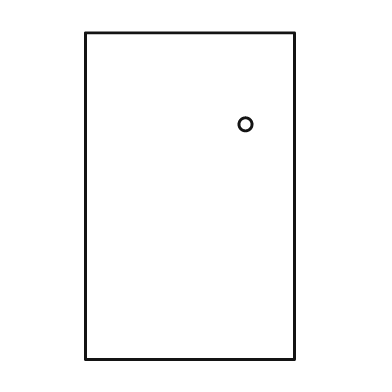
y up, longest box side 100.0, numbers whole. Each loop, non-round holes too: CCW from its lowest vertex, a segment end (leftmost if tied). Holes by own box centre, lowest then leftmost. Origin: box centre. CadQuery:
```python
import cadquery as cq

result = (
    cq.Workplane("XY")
    .moveTo(-32.0, -50.0)
    .lineTo(32.0, -50.0)
    .lineTo(32.0, 50.0)
    .lineTo(-32.0, 50.0)
    .close()
    .moveTo(17.0, 22.0)
    .circle(2.0)
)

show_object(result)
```